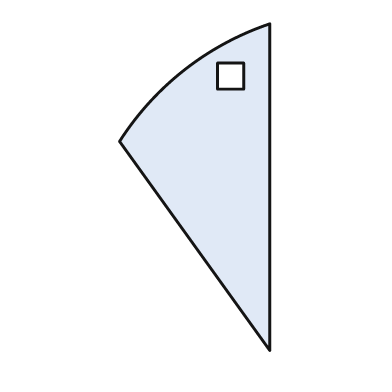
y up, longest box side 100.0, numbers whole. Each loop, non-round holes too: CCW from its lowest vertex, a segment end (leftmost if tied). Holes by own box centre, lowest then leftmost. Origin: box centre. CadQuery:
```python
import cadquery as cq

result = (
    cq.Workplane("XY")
    .moveTo(23.0, -50.0)
    .lineTo(23.0, 50.0)
    .threePointArc((-3.0, 36.0), (-23.0, 14.0))
    .close()
    .moveTo(7.0, 30.0)
    .lineTo(15.0, 30.0)
    .lineTo(15.0, 38.0)
    .lineTo(7.0, 38.0)
    .close()
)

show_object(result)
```